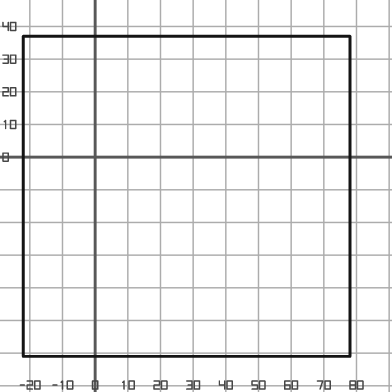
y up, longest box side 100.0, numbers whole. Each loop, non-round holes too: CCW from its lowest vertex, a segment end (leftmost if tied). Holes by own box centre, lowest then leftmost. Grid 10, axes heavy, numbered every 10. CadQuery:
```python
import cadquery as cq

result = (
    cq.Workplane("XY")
    .moveTo(-22.0, -61.0)
    .lineTo(78.0, -61.0)
    .lineTo(78.0, 37.0)
    .lineTo(-22.0, 37.0)
    .close()
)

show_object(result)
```